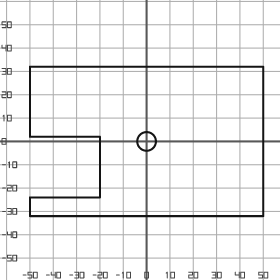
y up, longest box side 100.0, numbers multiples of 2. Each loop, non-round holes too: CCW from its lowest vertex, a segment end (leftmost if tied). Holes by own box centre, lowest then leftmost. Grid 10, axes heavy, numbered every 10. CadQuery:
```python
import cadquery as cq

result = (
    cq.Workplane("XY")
    .moveTo(-50.0, -32.0)
    .lineTo(50.0, -32.0)
    .lineTo(50.0, 32.0)
    .lineTo(-50.0, 32.0)
    .lineTo(-50.0, 2.0)
    .lineTo(-20.0, 2.0)
    .lineTo(-20.0, -24.0)
    .lineTo(-50.0, -24.0)
    .close()
    .moveTo(0.0, 0.0)
    .circle(4.0)
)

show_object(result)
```